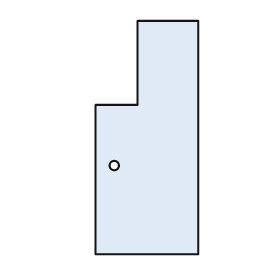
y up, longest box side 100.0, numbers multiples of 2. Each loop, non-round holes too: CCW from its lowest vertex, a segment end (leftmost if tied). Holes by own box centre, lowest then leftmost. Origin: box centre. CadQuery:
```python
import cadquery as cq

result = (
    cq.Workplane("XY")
    .moveTo(-22.0, -50.0)
    .lineTo(22.0, -50.0)
    .lineTo(22.0, 50.0)
    .lineTo(-4.0, 50.0)
    .lineTo(-4.0, 14.0)
    .lineTo(-22.0, 14.0)
    .close()
    .moveTo(-14.0, -12.0)
    .circle(2.0)
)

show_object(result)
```